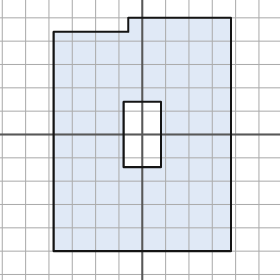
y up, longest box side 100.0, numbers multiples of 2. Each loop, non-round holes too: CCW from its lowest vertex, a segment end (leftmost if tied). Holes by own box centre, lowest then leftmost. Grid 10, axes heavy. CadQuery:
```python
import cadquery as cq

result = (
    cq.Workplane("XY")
    .moveTo(-38.0, -50.0)
    .lineTo(38.0, -50.0)
    .lineTo(38.0, 50.0)
    .lineTo(-6.0, 50.0)
    .lineTo(-6.0, 44.0)
    .lineTo(-38.0, 44.0)
    .close()
    .moveTo(-8.0, -14.0)
    .lineTo(8.0, -14.0)
    .lineTo(8.0, 14.0)
    .lineTo(-8.0, 14.0)
    .close()
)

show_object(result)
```